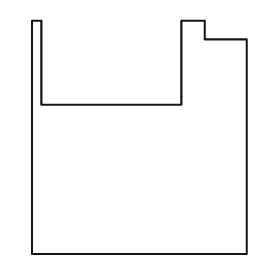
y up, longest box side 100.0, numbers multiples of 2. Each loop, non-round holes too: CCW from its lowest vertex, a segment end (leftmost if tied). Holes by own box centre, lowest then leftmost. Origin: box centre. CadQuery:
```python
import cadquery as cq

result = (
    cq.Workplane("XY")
    .moveTo(-46.0, -50.0)
    .lineTo(46.0, -50.0)
    .lineTo(46.0, 42.0)
    .lineTo(28.0, 42.0)
    .lineTo(28.0, 50.0)
    .lineTo(18.0, 50.0)
    .lineTo(18.0, 14.0)
    .lineTo(-42.0, 14.0)
    .lineTo(-42.0, 50.0)
    .lineTo(-46.0, 50.0)
    .close()
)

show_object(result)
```